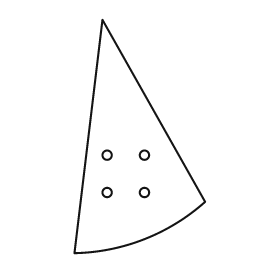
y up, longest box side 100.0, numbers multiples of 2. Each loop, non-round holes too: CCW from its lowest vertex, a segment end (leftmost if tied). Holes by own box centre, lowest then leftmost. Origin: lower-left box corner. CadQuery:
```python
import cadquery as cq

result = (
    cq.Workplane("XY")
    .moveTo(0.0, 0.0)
    .threePointArc((30.0, 6.0), (56.0, 22.0))
    .lineTo(12.0, 100.0)
    .close()
    .moveTo(14.0, 26.0)
    .circle(2.0)
    .moveTo(30.0, 26.0)
    .circle(2.0)
    .moveTo(14.0, 42.0)
    .circle(2.0)
    .moveTo(30.0, 42.0)
    .circle(2.0)
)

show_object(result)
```